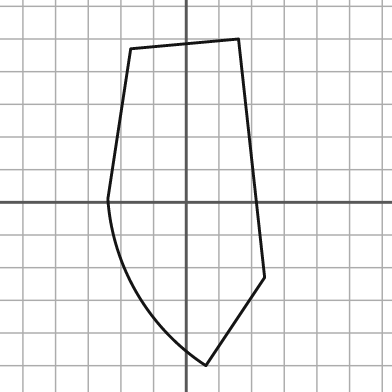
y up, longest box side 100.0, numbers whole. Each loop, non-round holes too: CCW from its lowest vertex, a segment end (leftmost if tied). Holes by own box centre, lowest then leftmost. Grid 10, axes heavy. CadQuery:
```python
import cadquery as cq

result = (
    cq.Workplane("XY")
    .moveTo(6.0, -50.0)
    .lineTo(24.0, -23.0)
    .lineTo(16.0, 50.0)
    .lineTo(-17.0, 47.0)
    .lineTo(-24.0, 1.0)
    .threePointArc((-15.0, -28.0), (6.0, -50.0))
    .close()
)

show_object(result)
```